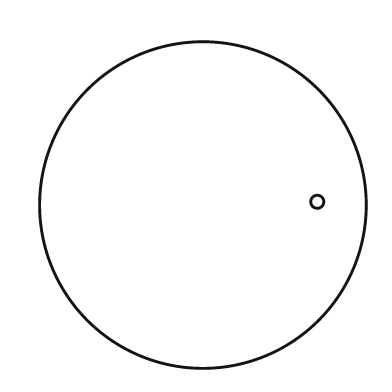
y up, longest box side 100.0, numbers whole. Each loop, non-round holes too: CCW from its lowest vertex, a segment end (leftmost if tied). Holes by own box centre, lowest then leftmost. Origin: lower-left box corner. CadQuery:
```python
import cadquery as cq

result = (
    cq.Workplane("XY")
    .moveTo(50.0, 50.0)
    .circle(50.0)
    .moveTo(85.0, 51.0)
    .circle(2.0)
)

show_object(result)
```